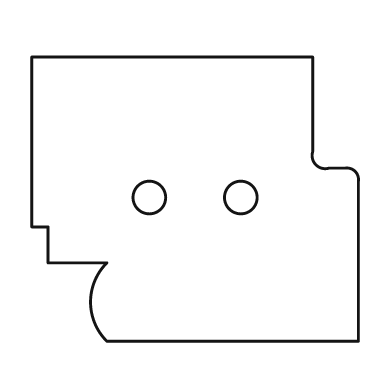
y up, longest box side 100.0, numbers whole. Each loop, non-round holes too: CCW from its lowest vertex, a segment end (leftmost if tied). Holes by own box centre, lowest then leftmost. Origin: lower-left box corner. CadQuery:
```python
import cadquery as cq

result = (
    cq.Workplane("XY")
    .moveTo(23.0, 0.0)
    .lineTo(100.0, 0.0)
    .lineTo(100.0, 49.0)
    .threePointArc((99.0, 52.0), (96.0, 53.0))
    .lineTo(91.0, 53.0)
    .threePointArc((87.0, 54.0), (86.0, 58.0))
    .lineTo(86.0, 87.0)
    .lineTo(0.0, 87.0)
    .lineTo(0.0, 35.0)
    .lineTo(5.0, 35.0)
    .lineTo(5.0, 24.0)
    .lineTo(23.0, 24.0)
    .threePointArc((18.0, 12.0), (23.0, 0.0))
    .close()
    .moveTo(36.0, 44.0)
    .circle(5.0)
    .moveTo(64.0, 44.0)
    .circle(5.0)
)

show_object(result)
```